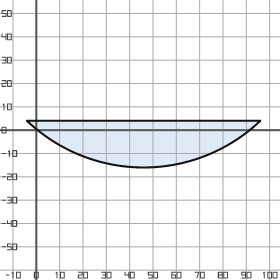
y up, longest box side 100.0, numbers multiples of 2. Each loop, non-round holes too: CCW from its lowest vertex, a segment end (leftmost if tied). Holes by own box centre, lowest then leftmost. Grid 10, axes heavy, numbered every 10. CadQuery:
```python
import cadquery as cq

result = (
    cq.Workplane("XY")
    .moveTo(-4.0, 4.0)
    .threePointArc((46.0, -16.0), (96.0, 4.0))
    .close()
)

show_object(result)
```